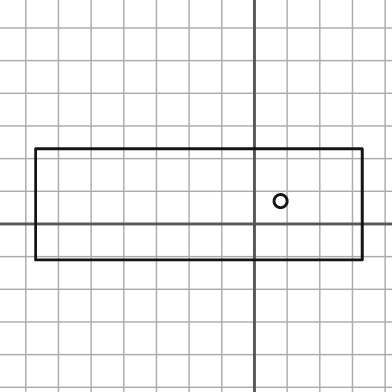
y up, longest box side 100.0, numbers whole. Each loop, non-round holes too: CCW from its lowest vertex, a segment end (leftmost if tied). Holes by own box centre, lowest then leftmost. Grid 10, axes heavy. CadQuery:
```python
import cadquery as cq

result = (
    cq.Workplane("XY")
    .moveTo(-67.0, -11.0)
    .lineTo(33.0, -11.0)
    .lineTo(33.0, 23.0)
    .lineTo(-67.0, 23.0)
    .close()
    .moveTo(8.0, 7.0)
    .circle(2.0)
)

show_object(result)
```